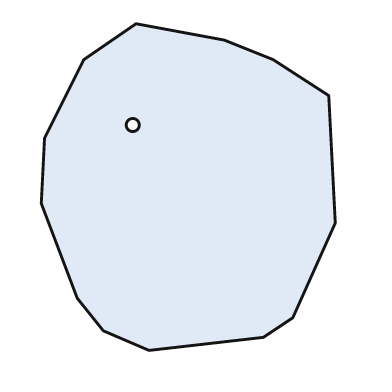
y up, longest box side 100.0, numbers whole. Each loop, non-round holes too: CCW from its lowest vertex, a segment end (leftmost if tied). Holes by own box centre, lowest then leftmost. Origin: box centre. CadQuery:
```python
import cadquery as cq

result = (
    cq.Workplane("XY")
    .moveTo(-12.0, -50.0)
    .lineTo(23.0, -46.0)
    .lineTo(32.0, -40.0)
    .lineTo(45.0, -11.0)
    .lineTo(43.0, 28.0)
    .lineTo(26.0, 39.0)
    .lineTo(11.0, 45.0)
    .lineTo(-16.0, 50.0)
    .lineTo(-32.0, 39.0)
    .lineTo(-44.0, 15.0)
    .lineTo(-45.0, -5.0)
    .lineTo(-34.0, -34.0)
    .lineTo(-26.0, -44.0)
    .close()
    .moveTo(-17.0, 19.0)
    .circle(2.0)
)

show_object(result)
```